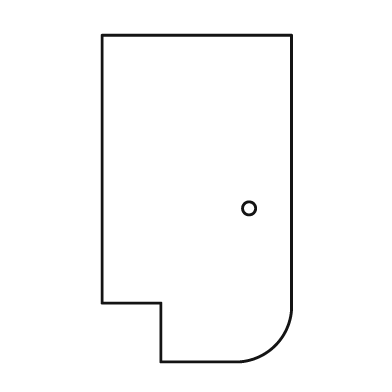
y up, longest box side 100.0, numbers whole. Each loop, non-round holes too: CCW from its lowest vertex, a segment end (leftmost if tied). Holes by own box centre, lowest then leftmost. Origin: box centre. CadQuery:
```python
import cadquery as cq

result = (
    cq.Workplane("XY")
    .moveTo(-11.0, -50.0)
    .lineTo(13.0, -50.0)
    .threePointArc((24.0, -45.0), (29.0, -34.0))
    .lineTo(29.0, 50.0)
    .lineTo(-29.0, 50.0)
    .lineTo(-29.0, -32.0)
    .lineTo(-11.0, -32.0)
    .close()
    .moveTo(16.0, -3.0)
    .circle(2.0)
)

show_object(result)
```